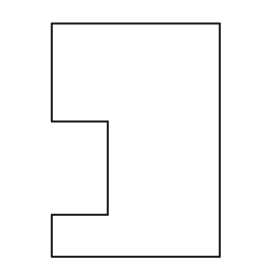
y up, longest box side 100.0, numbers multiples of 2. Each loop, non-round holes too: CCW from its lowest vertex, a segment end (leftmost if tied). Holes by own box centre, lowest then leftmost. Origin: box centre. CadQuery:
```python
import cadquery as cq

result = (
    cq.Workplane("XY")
    .moveTo(-36.0, -50.0)
    .lineTo(36.0, -50.0)
    .lineTo(36.0, 50.0)
    .lineTo(-36.0, 50.0)
    .lineTo(-36.0, 8.0)
    .lineTo(-12.0, 8.0)
    .lineTo(-12.0, -32.0)
    .lineTo(-36.0, -32.0)
    .close()
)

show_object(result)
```